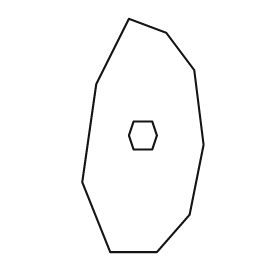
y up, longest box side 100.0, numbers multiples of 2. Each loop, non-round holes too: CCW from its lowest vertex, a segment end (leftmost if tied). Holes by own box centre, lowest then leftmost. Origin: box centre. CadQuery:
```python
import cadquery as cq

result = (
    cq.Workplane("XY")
    .moveTo(-14.0, -50.0)
    .lineTo(6.0, -50.0)
    .lineTo(20.0, -34.0)
    .lineTo(26.0, -4.0)
    .lineTo(22.0, 28.0)
    .lineTo(10.0, 44.0)
    .lineTo(-6.0, 50.0)
    .lineTo(-20.0, 22.0)
    .lineTo(-26.0, -20.0)
    .close()
    .moveTo(-4.0, -6.0)
    .lineTo(4.0, -6.0)
    .lineTo(6.0, 0.0)
    .lineTo(4.0, 6.0)
    .lineTo(-4.0, 6.0)
    .lineTo(-6.0, 0.0)
    .close()
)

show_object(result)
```